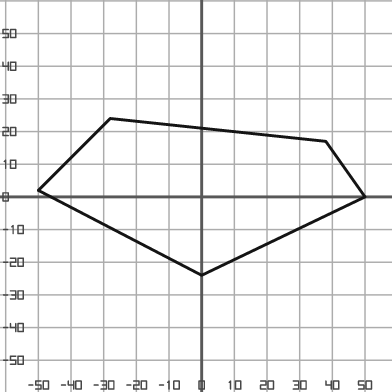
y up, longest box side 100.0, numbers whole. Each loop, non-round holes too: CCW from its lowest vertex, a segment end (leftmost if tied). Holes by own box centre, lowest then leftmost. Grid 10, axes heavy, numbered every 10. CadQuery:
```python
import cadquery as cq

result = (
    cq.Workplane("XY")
    .moveTo(0.0, -24.0)
    .lineTo(50.0, 0.0)
    .lineTo(38.0, 17.0)
    .lineTo(-28.0, 24.0)
    .lineTo(-50.0, 2.0)
    .close()
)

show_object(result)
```